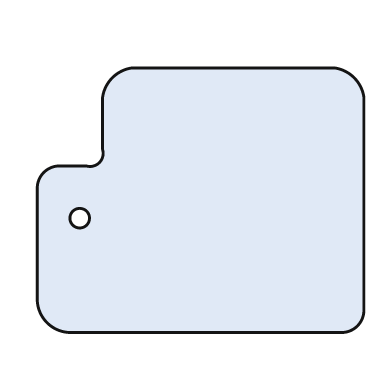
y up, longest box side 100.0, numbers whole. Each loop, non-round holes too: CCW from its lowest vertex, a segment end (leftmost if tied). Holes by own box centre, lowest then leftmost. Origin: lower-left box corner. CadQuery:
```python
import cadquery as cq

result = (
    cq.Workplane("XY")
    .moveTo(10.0, 0.0)
    .lineTo(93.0, 0.0)
    .threePointArc((98.0, 2.0), (100.0, 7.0))
    .lineTo(100.0, 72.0)
    .threePointArc((97.0, 78.0), (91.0, 81.0))
    .lineTo(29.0, 81.0)
    .threePointArc((23.0, 78.0), (20.0, 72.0))
    .lineTo(20.0, 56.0)
    .threePointArc((19.0, 52.0), (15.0, 51.0))
    .lineTo(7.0, 51.0)
    .threePointArc((2.0, 49.0), (0.0, 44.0))
    .lineTo(0.0, 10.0)
    .threePointArc((3.0, 3.0), (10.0, 0.0))
    .close()
    .moveTo(13.0, 35.0)
    .circle(3.0)
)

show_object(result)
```